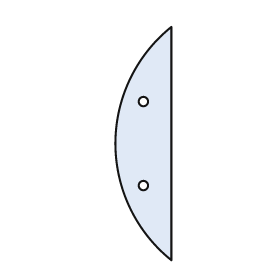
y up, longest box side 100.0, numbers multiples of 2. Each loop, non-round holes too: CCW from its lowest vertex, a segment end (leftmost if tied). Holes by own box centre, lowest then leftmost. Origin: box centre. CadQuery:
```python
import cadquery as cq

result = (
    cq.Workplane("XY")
    .moveTo(12.0, -50.0)
    .lineTo(12.0, 50.0)
    .threePointArc((-12.0, 0.0), (12.0, -50.0))
    .close()
    .moveTo(0.0, -18.0)
    .circle(2.0)
    .moveTo(0.0, 18.0)
    .circle(2.0)
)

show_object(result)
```